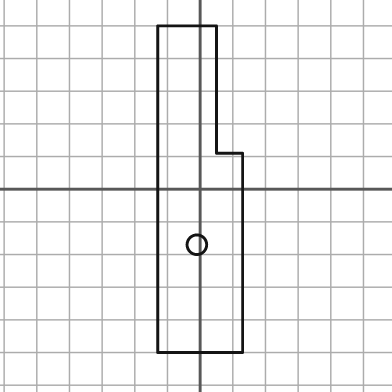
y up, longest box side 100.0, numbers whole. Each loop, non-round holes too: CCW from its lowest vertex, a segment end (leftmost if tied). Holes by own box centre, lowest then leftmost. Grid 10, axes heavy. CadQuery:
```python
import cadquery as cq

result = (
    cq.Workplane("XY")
    .moveTo(-13.0, -50.0)
    .lineTo(13.0, -50.0)
    .lineTo(13.0, 11.0)
    .lineTo(5.0, 11.0)
    .lineTo(5.0, 50.0)
    .lineTo(-13.0, 50.0)
    .close()
    .moveTo(-1.0, -17.0)
    .circle(3.0)
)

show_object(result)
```